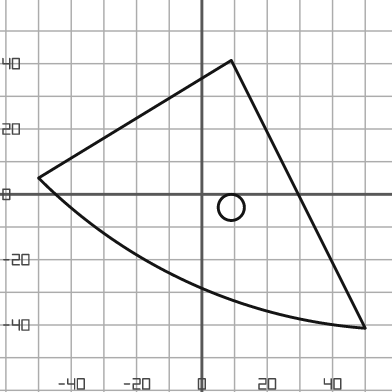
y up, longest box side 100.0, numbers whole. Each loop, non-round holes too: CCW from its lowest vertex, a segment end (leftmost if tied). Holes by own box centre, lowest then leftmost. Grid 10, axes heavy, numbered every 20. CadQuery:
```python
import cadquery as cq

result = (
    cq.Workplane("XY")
    .moveTo(50.0, -41.0)
    .lineTo(9.0, 41.0)
    .lineTo(-50.0, 5.0)
    .threePointArc((-4.0, -27.0), (50.0, -41.0))
    .close()
    .moveTo(9.0, -4.0)
    .circle(4.0)
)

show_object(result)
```